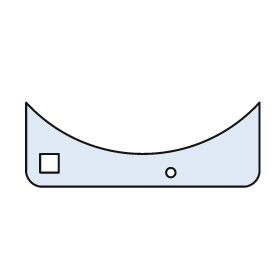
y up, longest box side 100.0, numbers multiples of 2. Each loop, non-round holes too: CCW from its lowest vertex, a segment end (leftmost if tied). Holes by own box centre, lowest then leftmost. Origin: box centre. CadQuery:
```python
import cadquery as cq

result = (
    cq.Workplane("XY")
    .moveTo(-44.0, -18.0)
    .lineTo(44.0, -18.0)
    .threePointArc((48.0, -16.0), (50.0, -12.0))
    .lineTo(50.0, 18.0)
    .threePointArc((0.0, -4.0), (-50.0, 18.0))
    .lineTo(-50.0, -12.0)
    .threePointArc((-48.0, -16.0), (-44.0, -18.0))
    .close()
    .moveTo(12.0, -12.0)
    .circle(2.0)
    .moveTo(-44.0, -12.0)
    .lineTo(-36.0, -12.0)
    .lineTo(-36.0, -4.0)
    .lineTo(-44.0, -4.0)
    .close()
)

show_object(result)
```